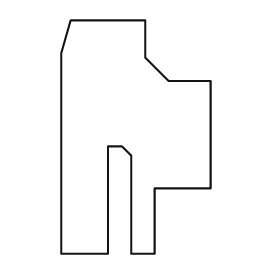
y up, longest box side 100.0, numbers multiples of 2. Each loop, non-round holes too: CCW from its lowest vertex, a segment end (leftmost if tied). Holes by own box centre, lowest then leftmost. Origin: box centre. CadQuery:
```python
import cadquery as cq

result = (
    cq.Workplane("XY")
    .moveTo(-32.0, -50.0)
    .lineTo(-12.0, -50.0)
    .lineTo(-12.0, -4.0)
    .lineTo(-6.0, -4.0)
    .lineTo(-2.0, -8.0)
    .lineTo(-2.0, -50.0)
    .lineTo(8.0, -50.0)
    .lineTo(8.0, -22.0)
    .lineTo(32.0, -22.0)
    .lineTo(32.0, 24.0)
    .lineTo(14.0, 24.0)
    .lineTo(4.0, 34.0)
    .lineTo(4.0, 50.0)
    .lineTo(-28.0, 50.0)
    .lineTo(-32.0, 36.0)
    .close()
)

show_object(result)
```